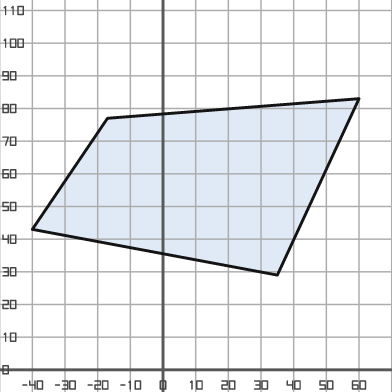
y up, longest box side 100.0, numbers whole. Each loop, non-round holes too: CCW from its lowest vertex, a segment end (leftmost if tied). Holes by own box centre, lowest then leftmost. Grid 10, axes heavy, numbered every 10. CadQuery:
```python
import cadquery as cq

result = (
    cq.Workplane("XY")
    .moveTo(35.0, 29.0)
    .lineTo(60.0, 83.0)
    .lineTo(-17.0, 77.0)
    .lineTo(-40.0, 43.0)
    .close()
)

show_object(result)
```